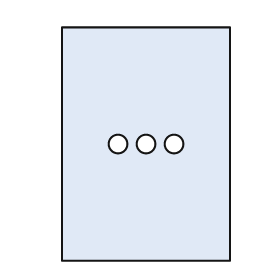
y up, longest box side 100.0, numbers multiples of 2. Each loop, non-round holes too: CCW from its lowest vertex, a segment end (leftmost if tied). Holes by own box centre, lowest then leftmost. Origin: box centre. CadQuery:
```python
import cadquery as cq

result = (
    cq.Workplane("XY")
    .moveTo(-36.0, -50.0)
    .lineTo(36.0, -50.0)
    .lineTo(36.0, 50.0)
    .lineTo(-36.0, 50.0)
    .close()
    .moveTo(-12.0, 0.0)
    .circle(4.0)
    .moveTo(0.0, 0.0)
    .circle(4.0)
    .moveTo(12.0, 0.0)
    .circle(4.0)
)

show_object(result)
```